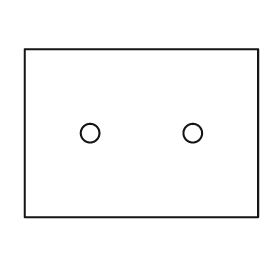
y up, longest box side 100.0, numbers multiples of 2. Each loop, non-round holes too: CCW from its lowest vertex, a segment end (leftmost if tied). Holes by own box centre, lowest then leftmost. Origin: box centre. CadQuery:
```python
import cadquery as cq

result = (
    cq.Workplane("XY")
    .moveTo(-50.0, -36.0)
    .lineTo(50.0, -36.0)
    .lineTo(50.0, 36.0)
    .lineTo(-50.0, 36.0)
    .close()
    .moveTo(-22.0, 0.0)
    .circle(4.0)
    .moveTo(22.0, 0.0)
    .circle(4.0)
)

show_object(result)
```